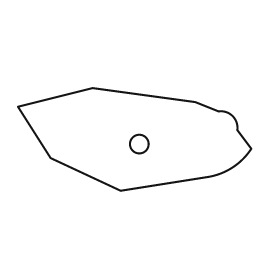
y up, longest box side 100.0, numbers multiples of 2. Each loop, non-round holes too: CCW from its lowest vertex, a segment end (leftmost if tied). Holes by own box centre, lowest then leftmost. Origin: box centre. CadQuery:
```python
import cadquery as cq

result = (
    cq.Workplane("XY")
    .moveTo(-6.0, -22.0)
    .lineTo(32.0, -16.0)
    .threePointArc((42.0, -12.0), (50.0, -4.0))
    .lineTo(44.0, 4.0)
    .threePointArc((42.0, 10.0), (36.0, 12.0))
    .lineTo(26.0, 16.0)
    .lineTo(-18.0, 22.0)
    .lineTo(-50.0, 14.0)
    .lineTo(-36.0, -8.0)
    .close()
    .moveTo(2.0, -2.0)
    .circle(4.0)
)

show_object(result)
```